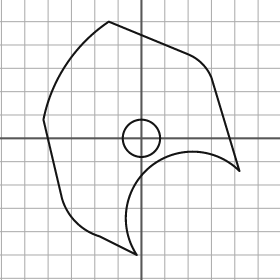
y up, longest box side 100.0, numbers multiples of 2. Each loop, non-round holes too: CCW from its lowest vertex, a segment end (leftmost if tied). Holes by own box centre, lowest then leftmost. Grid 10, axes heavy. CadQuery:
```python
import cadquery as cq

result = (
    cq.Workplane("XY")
    .moveTo(-2.0, -50.0)
    .threePointArc((4.0, -12.0), (42.0, -14.0))
    .lineTo(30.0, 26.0)
    .threePointArc((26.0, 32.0), (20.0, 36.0))
    .lineTo(-14.0, 50.0)
    .threePointArc((-32.0, 32.0), (-42.0, 8.0))
    .lineTo(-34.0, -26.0)
    .threePointArc((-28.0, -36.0), (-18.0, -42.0))
    .close()
    .moveTo(0.0, 0.0)
    .circle(8.0)
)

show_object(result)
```